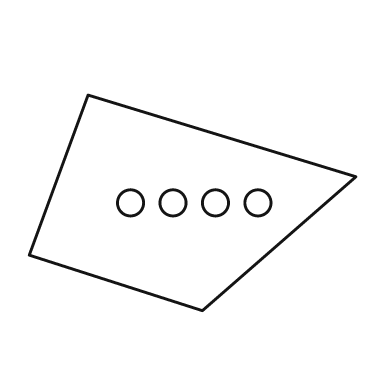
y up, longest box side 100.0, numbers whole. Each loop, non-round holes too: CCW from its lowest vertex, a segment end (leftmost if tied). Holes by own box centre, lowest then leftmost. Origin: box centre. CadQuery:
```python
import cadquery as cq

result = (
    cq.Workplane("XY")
    .moveTo(3.0, -33.0)
    .lineTo(50.0, 8.0)
    .lineTo(-32.0, 33.0)
    .lineTo(-50.0, -16.0)
    .close()
    .moveTo(-19.0, 0.0)
    .circle(4.0)
    .moveTo(-6.0, 0.0)
    .circle(4.0)
    .moveTo(7.0, 0.0)
    .circle(4.0)
    .moveTo(20.0, 0.0)
    .circle(4.0)
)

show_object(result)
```